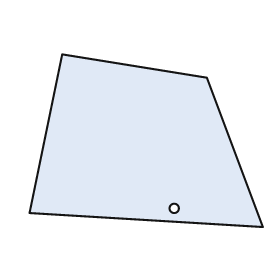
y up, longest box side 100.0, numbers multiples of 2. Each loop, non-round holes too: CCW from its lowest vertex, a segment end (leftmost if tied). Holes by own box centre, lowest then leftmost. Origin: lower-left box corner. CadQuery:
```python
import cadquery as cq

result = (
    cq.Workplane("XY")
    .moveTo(100.0, 0.0)
    .lineTo(76.0, 64.0)
    .lineTo(14.0, 74.0)
    .lineTo(0.0, 6.0)
    .close()
    .moveTo(62.0, 8.0)
    .circle(2.0)
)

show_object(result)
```